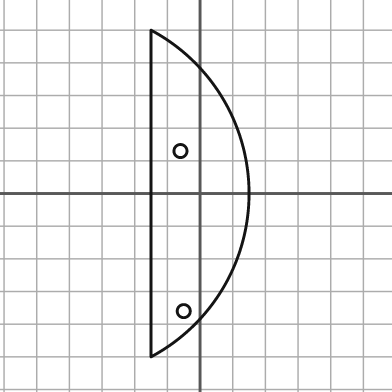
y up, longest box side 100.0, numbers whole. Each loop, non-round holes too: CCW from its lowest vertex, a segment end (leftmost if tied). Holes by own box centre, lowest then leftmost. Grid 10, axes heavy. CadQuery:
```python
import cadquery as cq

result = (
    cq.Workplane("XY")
    .moveTo(-15.0, -50.0)
    .threePointArc((15.0, 0.0), (-15.0, 50.0))
    .close()
    .moveTo(-5.0, -36.0)
    .circle(2.0)
    .moveTo(-6.0, 13.0)
    .circle(2.0)
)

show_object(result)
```